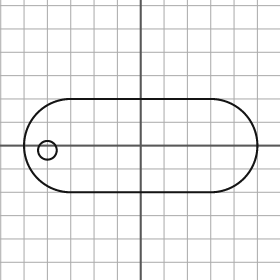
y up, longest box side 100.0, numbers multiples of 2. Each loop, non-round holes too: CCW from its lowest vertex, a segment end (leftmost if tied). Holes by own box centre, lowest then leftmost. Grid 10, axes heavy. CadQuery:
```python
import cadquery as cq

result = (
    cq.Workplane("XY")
    .moveTo(-30.0, -20.0)
    .lineTo(30.0, -20.0)
    .threePointArc((50.0, 0.0), (30.0, 20.0))
    .lineTo(-30.0, 20.0)
    .threePointArc((-50.0, 0.0), (-30.0, -20.0))
    .close()
    .moveTo(-40.0, -2.0)
    .circle(4.0)
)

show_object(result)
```